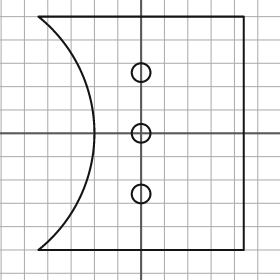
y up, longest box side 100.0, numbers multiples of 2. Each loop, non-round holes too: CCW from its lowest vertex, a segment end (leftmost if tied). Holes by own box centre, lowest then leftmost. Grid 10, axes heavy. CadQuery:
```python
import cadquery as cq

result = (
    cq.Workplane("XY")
    .moveTo(-44.0, -50.0)
    .lineTo(44.0, -50.0)
    .lineTo(44.0, 50.0)
    .lineTo(-44.0, 50.0)
    .threePointArc((-20.0, 0.0), (-44.0, -50.0))
    .close()
    .moveTo(0.0, -26.0)
    .circle(4.0)
    .moveTo(0.0, 0.0)
    .circle(4.0)
    .moveTo(0.0, 26.0)
    .circle(4.0)
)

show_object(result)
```